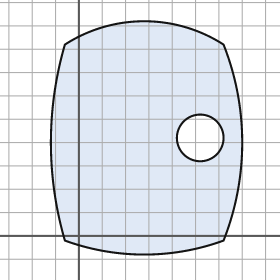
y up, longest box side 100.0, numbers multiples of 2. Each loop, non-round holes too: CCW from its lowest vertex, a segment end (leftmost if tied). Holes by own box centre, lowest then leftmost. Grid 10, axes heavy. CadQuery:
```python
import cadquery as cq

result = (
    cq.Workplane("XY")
    .moveTo(-6.0, -2.0)
    .threePointArc((28.0, -8.0), (62.0, -2.0))
    .threePointArc((70.0, 40.0), (62.0, 82.0))
    .threePointArc((28.0, 92.0), (-6.0, 82.0))
    .threePointArc((-12.0, 40.0), (-6.0, -2.0))
    .close()
    .moveTo(52.0, 42.0)
    .circle(10.0)
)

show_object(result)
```